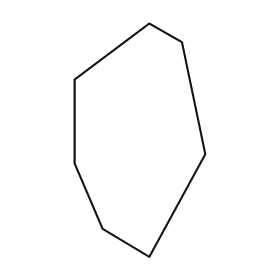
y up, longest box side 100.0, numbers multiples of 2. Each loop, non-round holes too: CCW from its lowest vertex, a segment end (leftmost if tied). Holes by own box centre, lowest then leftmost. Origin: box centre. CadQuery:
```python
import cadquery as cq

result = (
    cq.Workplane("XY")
    .moveTo(4.0, -50.0)
    .lineTo(28.0, -6.0)
    .lineTo(18.0, 42.0)
    .lineTo(4.0, 50.0)
    .lineTo(-28.0, 26.0)
    .lineTo(-28.0, -10.0)
    .lineTo(-16.0, -38.0)
    .close()
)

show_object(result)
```